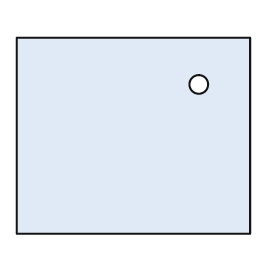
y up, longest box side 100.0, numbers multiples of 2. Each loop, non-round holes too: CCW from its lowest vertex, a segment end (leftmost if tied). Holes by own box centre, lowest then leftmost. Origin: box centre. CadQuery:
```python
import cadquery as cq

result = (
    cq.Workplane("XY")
    .moveTo(-50.0, -42.0)
    .lineTo(50.0, -42.0)
    .lineTo(50.0, 42.0)
    .lineTo(-50.0, 42.0)
    .close()
    .moveTo(28.0, 22.0)
    .circle(4.0)
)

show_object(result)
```